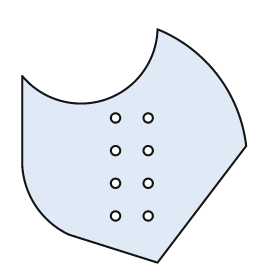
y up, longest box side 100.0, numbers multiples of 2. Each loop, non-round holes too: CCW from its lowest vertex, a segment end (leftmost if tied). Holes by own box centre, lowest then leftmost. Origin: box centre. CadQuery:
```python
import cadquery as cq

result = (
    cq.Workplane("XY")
    .moveTo(10.0, -50.0)
    .lineTo(48.0, 0.0)
    .threePointArc((36.0, 30.0), (10.0, 50.0))
    .threePointArc((-12.0, 20.0), (-48.0, 30.0))
    .lineTo(-48.0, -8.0)
    .threePointArc((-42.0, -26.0), (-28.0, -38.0))
    .close()
    .moveTo(-8.0, -30.0)
    .circle(2.0)
    .moveTo(6.0, -30.0)
    .circle(2.0)
    .moveTo(-8.0, -16.0)
    .circle(2.0)
    .moveTo(6.0, -16.0)
    .circle(2.0)
    .moveTo(-8.0, -2.0)
    .circle(2.0)
    .moveTo(6.0, -2.0)
    .circle(2.0)
    .moveTo(-8.0, 12.0)
    .circle(2.0)
    .moveTo(6.0, 12.0)
    .circle(2.0)
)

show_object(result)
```